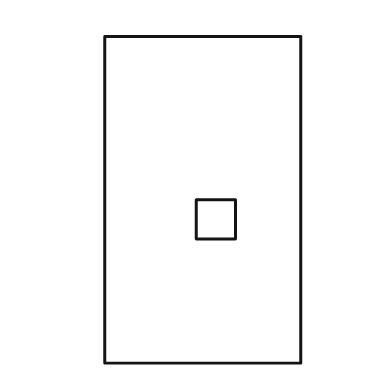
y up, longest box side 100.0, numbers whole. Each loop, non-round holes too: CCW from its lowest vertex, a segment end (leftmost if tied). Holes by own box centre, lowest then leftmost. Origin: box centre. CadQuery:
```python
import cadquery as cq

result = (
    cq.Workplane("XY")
    .moveTo(-30.0, -50.0)
    .lineTo(30.0, -50.0)
    .lineTo(30.0, 50.0)
    .lineTo(-30.0, 50.0)
    .close()
    .moveTo(-2.0, -12.0)
    .lineTo(10.0, -12.0)
    .lineTo(10.0, 0.0)
    .lineTo(-2.0, 0.0)
    .close()
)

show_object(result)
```